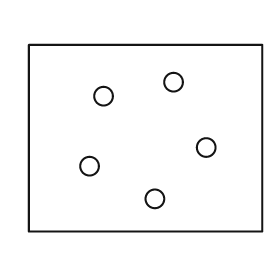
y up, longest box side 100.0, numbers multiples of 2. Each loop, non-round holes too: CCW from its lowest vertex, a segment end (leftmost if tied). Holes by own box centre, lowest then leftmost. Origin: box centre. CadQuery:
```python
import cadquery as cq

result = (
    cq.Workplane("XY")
    .moveTo(-50.0, -40.0)
    .lineTo(50.0, -40.0)
    .lineTo(50.0, 40.0)
    .lineTo(-50.0, 40.0)
    .close()
    .moveTo(4.0, -26.0)
    .circle(4.0)
    .moveTo(-24.0, -12.0)
    .circle(4.0)
    .moveTo(26.0, -4.0)
    .circle(4.0)
    .moveTo(-18.0, 18.0)
    .circle(4.0)
    .moveTo(12.0, 24.0)
    .circle(4.0)
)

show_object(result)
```